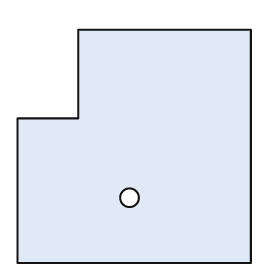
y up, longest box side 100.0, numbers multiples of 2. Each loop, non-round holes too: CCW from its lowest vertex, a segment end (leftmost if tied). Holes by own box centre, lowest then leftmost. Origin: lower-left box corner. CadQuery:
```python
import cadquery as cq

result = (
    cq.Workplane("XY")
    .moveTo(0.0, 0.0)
    .lineTo(100.0, 0.0)
    .lineTo(100.0, 100.0)
    .lineTo(26.0, 100.0)
    .lineTo(26.0, 62.0)
    .lineTo(0.0, 62.0)
    .close()
    .moveTo(48.0, 28.0)
    .circle(4.0)
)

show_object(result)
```